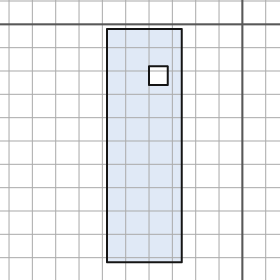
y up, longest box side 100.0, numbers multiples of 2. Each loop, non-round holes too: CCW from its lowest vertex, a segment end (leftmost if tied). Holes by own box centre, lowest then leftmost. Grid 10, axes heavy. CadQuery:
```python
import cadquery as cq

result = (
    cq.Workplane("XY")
    .moveTo(-58.0, -102.0)
    .lineTo(-26.0, -102.0)
    .lineTo(-26.0, -2.0)
    .lineTo(-58.0, -2.0)
    .close()
    .moveTo(-40.0, -26.0)
    .lineTo(-32.0, -26.0)
    .lineTo(-32.0, -18.0)
    .lineTo(-40.0, -18.0)
    .close()
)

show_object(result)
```